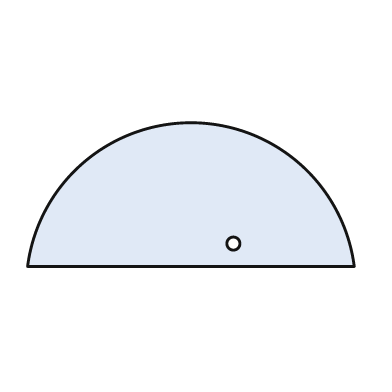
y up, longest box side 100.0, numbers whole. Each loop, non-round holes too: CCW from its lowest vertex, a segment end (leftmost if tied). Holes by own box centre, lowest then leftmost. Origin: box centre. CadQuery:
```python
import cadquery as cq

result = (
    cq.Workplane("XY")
    .moveTo(-50.0, -22.0)
    .lineTo(50.0, -22.0)
    .threePointArc((0.0, 22.0), (-50.0, -22.0))
    .close()
    .moveTo(13.0, -15.0)
    .circle(2.0)
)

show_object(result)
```